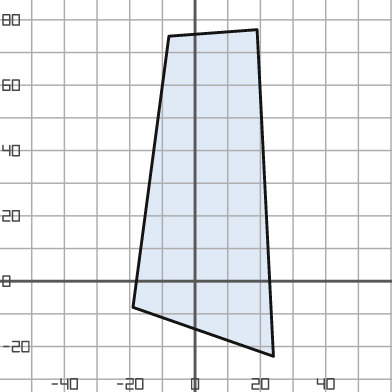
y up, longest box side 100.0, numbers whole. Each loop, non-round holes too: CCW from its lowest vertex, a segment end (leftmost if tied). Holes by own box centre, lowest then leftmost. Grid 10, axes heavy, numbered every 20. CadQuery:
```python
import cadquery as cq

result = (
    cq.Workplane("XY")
    .moveTo(24.0, -23.0)
    .lineTo(19.0, 77.0)
    .lineTo(-8.0, 75.0)
    .lineTo(-19.0, -8.0)
    .close()
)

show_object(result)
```